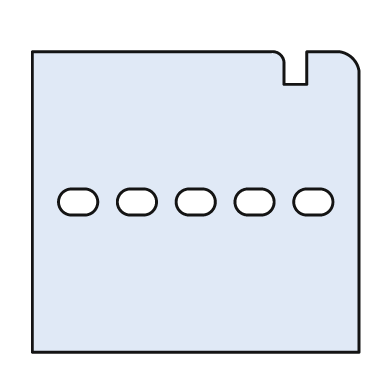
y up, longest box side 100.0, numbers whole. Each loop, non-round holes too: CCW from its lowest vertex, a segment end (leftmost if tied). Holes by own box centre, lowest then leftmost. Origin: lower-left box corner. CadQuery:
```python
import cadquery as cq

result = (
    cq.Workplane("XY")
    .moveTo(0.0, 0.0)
    .lineTo(100.0, 0.0)
    .lineTo(100.0, 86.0)
    .threePointArc((98.0, 90.0), (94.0, 92.0))
    .lineTo(84.0, 92.0)
    .lineTo(84.0, 82.0)
    .lineTo(77.0, 82.0)
    .lineTo(77.0, 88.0)
    .threePointArc((76.0, 91.0), (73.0, 92.0))
    .lineTo(0.0, 92.0)
    .close()
    .moveTo(12.0, 42.0)
    .lineTo(16.0, 42.0)
    .threePointArc((20.0, 46.0), (16.0, 50.0))
    .lineTo(12.0, 50.0)
    .threePointArc((8.0, 46.0), (12.0, 42.0))
    .close()
    .moveTo(30.0, 42.0)
    .lineTo(34.0, 42.0)
    .threePointArc((38.0, 46.0), (34.0, 50.0))
    .lineTo(30.0, 50.0)
    .threePointArc((26.0, 46.0), (30.0, 42.0))
    .close()
    .moveTo(48.0, 42.0)
    .lineTo(52.0, 42.0)
    .threePointArc((56.0, 46.0), (52.0, 50.0))
    .lineTo(48.0, 50.0)
    .threePointArc((44.0, 46.0), (48.0, 42.0))
    .close()
    .moveTo(66.0, 42.0)
    .lineTo(70.0, 42.0)
    .threePointArc((74.0, 46.0), (70.0, 50.0))
    .lineTo(66.0, 50.0)
    .threePointArc((62.0, 46.0), (66.0, 42.0))
    .close()
    .moveTo(84.0, 42.0)
    .lineTo(88.0, 42.0)
    .threePointArc((92.0, 46.0), (88.0, 50.0))
    .lineTo(84.0, 50.0)
    .threePointArc((80.0, 46.0), (84.0, 42.0))
    .close()
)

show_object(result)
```